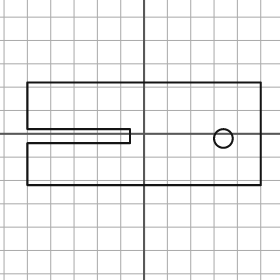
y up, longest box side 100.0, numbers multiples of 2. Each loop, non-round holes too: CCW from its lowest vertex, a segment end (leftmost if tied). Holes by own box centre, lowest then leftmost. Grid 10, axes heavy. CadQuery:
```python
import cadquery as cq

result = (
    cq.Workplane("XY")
    .moveTo(-50.0, -22.0)
    .lineTo(50.0, -22.0)
    .lineTo(50.0, 22.0)
    .lineTo(-50.0, 22.0)
    .lineTo(-50.0, 2.0)
    .lineTo(-6.0, 2.0)
    .lineTo(-6.0, -4.0)
    .lineTo(-50.0, -4.0)
    .close()
    .moveTo(34.0, -2.0)
    .circle(4.0)
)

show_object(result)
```